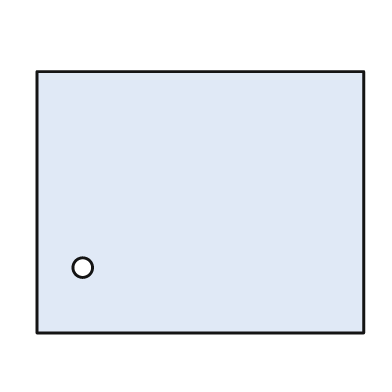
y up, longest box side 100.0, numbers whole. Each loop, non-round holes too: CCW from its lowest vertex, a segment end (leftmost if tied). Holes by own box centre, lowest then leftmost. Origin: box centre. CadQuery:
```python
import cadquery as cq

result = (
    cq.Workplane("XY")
    .moveTo(-50.0, -40.0)
    .lineTo(50.0, -40.0)
    .lineTo(50.0, 40.0)
    .lineTo(-50.0, 40.0)
    .close()
    .moveTo(-36.0, -20.0)
    .circle(3.0)
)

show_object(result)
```